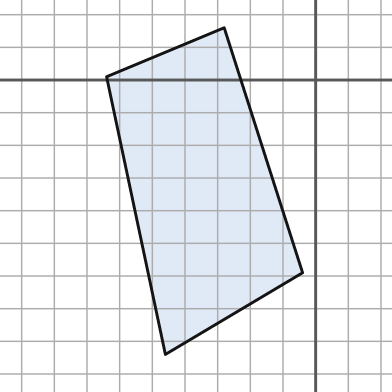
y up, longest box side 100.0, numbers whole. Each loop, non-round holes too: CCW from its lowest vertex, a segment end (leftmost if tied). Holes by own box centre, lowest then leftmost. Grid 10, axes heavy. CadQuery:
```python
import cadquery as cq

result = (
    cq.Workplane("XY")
    .moveTo(-46.0, -84.0)
    .lineTo(-4.0, -59.0)
    .lineTo(-28.0, 16.0)
    .lineTo(-64.0, 1.0)
    .close()
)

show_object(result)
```